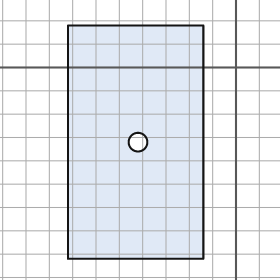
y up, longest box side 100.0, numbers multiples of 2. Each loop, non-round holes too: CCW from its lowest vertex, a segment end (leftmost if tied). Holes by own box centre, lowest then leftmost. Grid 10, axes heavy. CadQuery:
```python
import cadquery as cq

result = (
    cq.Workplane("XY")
    .moveTo(-72.0, -82.0)
    .lineTo(-14.0, -82.0)
    .lineTo(-14.0, 18.0)
    .lineTo(-72.0, 18.0)
    .close()
    .moveTo(-42.0, -32.0)
    .circle(4.0)
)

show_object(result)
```